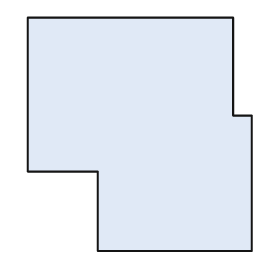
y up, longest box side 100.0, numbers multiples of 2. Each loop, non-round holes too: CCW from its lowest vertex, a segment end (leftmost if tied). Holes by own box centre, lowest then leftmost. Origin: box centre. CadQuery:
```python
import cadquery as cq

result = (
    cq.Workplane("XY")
    .moveTo(-18.0, -50.0)
    .lineTo(48.0, -50.0)
    .lineTo(48.0, 8.0)
    .lineTo(40.0, 8.0)
    .lineTo(40.0, 50.0)
    .lineTo(-48.0, 50.0)
    .lineTo(-48.0, -16.0)
    .lineTo(-18.0, -16.0)
    .close()
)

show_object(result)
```